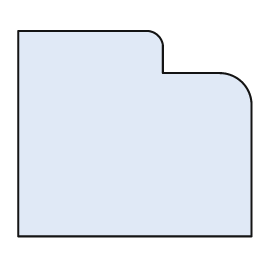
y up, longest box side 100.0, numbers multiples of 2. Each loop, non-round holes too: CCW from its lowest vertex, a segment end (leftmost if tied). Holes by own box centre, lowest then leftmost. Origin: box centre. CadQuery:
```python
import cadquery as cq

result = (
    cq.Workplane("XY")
    .moveTo(-50.0, -44.0)
    .lineTo(50.0, -44.0)
    .lineTo(50.0, 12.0)
    .threePointArc((46.0, 22.0), (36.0, 26.0))
    .lineTo(12.0, 26.0)
    .lineTo(12.0, 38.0)
    .threePointArc((10.0, 42.0), (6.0, 44.0))
    .lineTo(-50.0, 44.0)
    .close()
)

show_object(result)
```